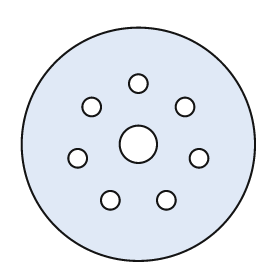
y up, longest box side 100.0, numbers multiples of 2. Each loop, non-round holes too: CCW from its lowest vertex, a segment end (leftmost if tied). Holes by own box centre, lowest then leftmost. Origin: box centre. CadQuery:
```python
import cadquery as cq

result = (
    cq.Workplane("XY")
    .moveTo(0.0, 0.0)
    .circle(50.0)
    .moveTo(-12.0, -24.0)
    .circle(4.0)
    .moveTo(12.0, -24.0)
    .circle(4.0)
    .moveTo(-26.0, -6.0)
    .circle(4.0)
    .moveTo(26.0, -6.0)
    .circle(4.0)
    .moveTo(0.0, 0.0)
    .circle(8.0)
    .moveTo(-20.0, 16.0)
    .circle(4.0)
    .moveTo(20.0, 16.0)
    .circle(4.0)
    .moveTo(0.0, 26.0)
    .circle(4.0)
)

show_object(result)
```